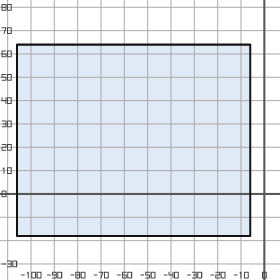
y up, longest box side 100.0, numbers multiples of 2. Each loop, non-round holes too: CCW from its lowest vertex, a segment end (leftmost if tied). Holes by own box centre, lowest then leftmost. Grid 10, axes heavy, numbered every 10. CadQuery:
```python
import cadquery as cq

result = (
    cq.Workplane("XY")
    .moveTo(-106.0, -18.0)
    .lineTo(-6.0, -18.0)
    .lineTo(-6.0, 64.0)
    .lineTo(-106.0, 64.0)
    .close()
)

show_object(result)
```